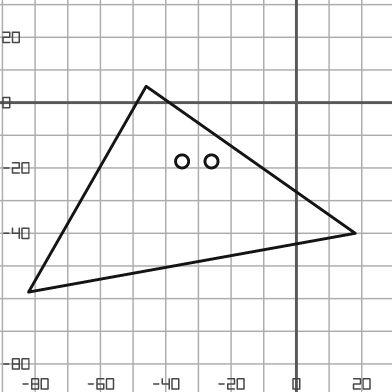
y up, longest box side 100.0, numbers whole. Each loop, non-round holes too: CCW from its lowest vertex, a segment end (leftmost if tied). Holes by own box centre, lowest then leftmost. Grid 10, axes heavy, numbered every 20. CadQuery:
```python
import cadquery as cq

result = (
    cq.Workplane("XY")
    .moveTo(-82.0, -58.0)
    .lineTo(18.0, -40.0)
    .lineTo(-46.0, 5.0)
    .close()
    .moveTo(-35.0, -18.0)
    .circle(2.0)
    .moveTo(-26.0, -18.0)
    .circle(2.0)
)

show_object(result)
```